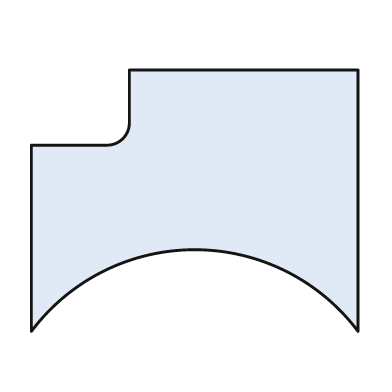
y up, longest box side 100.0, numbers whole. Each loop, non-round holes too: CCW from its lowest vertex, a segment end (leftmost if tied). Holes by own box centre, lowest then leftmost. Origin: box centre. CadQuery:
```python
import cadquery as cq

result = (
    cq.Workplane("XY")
    .moveTo(-50.0, -40.0)
    .threePointArc((0.0, -15.0), (50.0, -40.0))
    .lineTo(50.0, 40.0)
    .lineTo(-20.0, 40.0)
    .lineTo(-20.0, 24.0)
    .threePointArc((-22.0, 19.0), (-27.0, 17.0))
    .lineTo(-50.0, 17.0)
    .close()
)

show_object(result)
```